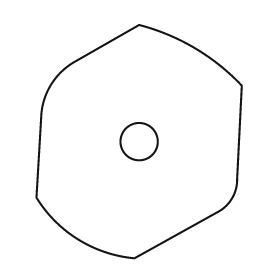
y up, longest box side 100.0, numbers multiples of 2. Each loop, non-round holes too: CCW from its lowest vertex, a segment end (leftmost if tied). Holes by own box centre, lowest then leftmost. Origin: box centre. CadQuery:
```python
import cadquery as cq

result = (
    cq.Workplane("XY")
    .moveTo(-2.0, -50.0)
    .lineTo(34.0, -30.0)
    .threePointArc((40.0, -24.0), (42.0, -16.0))
    .lineTo(44.0, 24.0)
    .threePointArc((24.0, 40.0), (0.0, 50.0))
    .lineTo(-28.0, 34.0)
    .threePointArc((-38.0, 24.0), (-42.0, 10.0))
    .lineTo(-44.0, -24.0)
    .threePointArc((-26.0, -42.0), (-2.0, -50.0))
    .close()
    .moveTo(0.0, 0.0)
    .circle(8.0)
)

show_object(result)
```